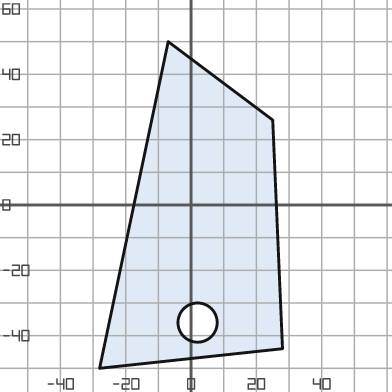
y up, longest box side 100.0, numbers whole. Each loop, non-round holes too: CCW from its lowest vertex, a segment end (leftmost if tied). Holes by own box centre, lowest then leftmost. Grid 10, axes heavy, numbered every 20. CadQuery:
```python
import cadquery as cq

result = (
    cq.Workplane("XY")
    .moveTo(-28.0, -50.0)
    .lineTo(28.0, -44.0)
    .lineTo(25.0, 26.0)
    .lineTo(-7.0, 50.0)
    .close()
    .moveTo(2.0, -36.0)
    .circle(6.0)
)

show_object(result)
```